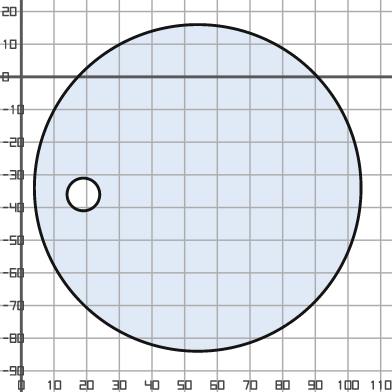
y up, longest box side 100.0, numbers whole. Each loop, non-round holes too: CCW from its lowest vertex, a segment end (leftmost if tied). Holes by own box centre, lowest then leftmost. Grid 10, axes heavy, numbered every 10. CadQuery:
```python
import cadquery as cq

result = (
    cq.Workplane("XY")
    .moveTo(54.0, -34.0)
    .circle(50.0)
    .moveTo(19.0, -36.0)
    .circle(5.0)
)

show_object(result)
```